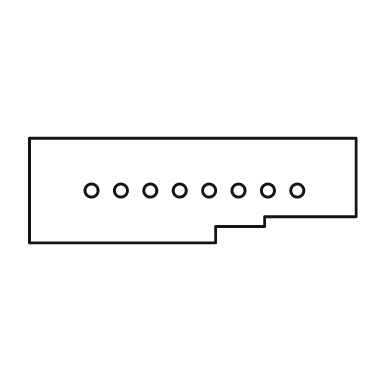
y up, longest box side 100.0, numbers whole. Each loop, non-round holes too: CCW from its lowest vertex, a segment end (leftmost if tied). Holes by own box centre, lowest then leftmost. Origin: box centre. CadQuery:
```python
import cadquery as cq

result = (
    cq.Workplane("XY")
    .moveTo(-50.0, -16.0)
    .lineTo(7.0, -16.0)
    .lineTo(7.0, -11.0)
    .lineTo(22.0, -11.0)
    .lineTo(22.0, -8.0)
    .lineTo(50.0, -8.0)
    .lineTo(50.0, 16.0)
    .lineTo(-50.0, 16.0)
    .close()
    .moveTo(-31.0, 0.0)
    .circle(2.0)
    .moveTo(-22.0, 0.0)
    .circle(2.0)
    .moveTo(-13.0, 0.0)
    .circle(2.0)
    .moveTo(-4.0, 0.0)
    .circle(2.0)
    .moveTo(5.0, 0.0)
    .circle(2.0)
    .moveTo(14.0, 0.0)
    .circle(2.0)
    .moveTo(23.0, 0.0)
    .circle(2.0)
    .moveTo(32.0, 0.0)
    .circle(2.0)
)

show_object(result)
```